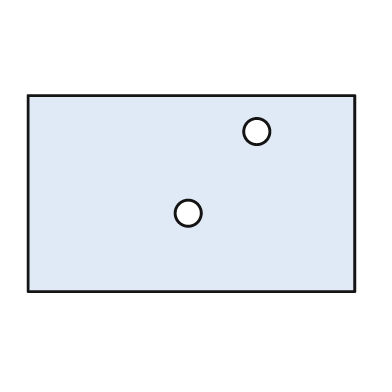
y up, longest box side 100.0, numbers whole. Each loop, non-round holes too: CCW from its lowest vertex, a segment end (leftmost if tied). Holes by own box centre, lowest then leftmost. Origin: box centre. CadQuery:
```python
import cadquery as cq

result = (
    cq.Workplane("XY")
    .moveTo(-50.0, -30.0)
    .lineTo(50.0, -30.0)
    .lineTo(50.0, 30.0)
    .lineTo(-50.0, 30.0)
    .close()
    .moveTo(-1.0, -6.0)
    .circle(4.0)
    .moveTo(20.0, 19.0)
    .circle(4.0)
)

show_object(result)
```